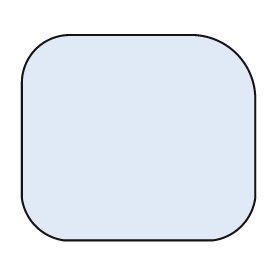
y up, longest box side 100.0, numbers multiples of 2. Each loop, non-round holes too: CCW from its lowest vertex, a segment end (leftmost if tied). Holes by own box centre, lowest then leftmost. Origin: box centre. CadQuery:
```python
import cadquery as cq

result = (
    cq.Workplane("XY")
    .moveTo(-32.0, -44.0)
    .lineTo(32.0, -44.0)
    .threePointArc((44.0, -38.0), (50.0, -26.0))
    .lineTo(50.0, 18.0)
    .threePointArc((42.0, 36.0), (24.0, 44.0))
    .lineTo(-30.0, 44.0)
    .threePointArc((-44.0, 38.0), (-50.0, 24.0))
    .lineTo(-50.0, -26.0)
    .threePointArc((-44.0, -38.0), (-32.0, -44.0))
    .close()
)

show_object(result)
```